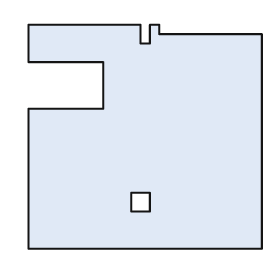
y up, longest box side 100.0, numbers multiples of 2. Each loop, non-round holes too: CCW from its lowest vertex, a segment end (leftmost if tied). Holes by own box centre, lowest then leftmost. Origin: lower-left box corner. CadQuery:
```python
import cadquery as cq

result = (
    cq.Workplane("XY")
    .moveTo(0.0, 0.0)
    .lineTo(100.0, 0.0)
    .lineTo(100.0, 92.0)
    .lineTo(56.0, 92.0)
    .lineTo(56.0, 96.0)
    .lineTo(52.0, 96.0)
    .lineTo(52.0, 88.0)
    .lineTo(48.0, 88.0)
    .lineTo(48.0, 96.0)
    .lineTo(0.0, 96.0)
    .lineTo(0.0, 80.0)
    .lineTo(32.0, 80.0)
    .lineTo(32.0, 60.0)
    .lineTo(0.0, 60.0)
    .close()
    .moveTo(44.0, 16.0)
    .lineTo(52.0, 16.0)
    .lineTo(52.0, 24.0)
    .lineTo(44.0, 24.0)
    .close()
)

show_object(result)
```